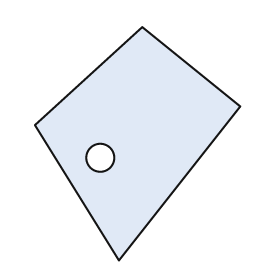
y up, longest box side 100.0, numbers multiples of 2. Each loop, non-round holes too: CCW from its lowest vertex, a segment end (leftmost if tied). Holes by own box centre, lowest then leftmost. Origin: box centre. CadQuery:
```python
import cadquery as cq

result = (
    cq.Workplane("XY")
    .moveTo(-8.0, -50.0)
    .lineTo(44.0, 16.0)
    .lineTo(2.0, 50.0)
    .lineTo(-44.0, 8.0)
    .close()
    .moveTo(-16.0, -6.0)
    .circle(6.0)
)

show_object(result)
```